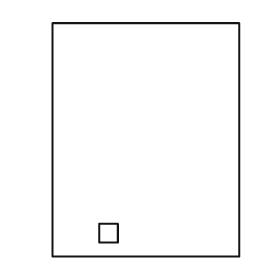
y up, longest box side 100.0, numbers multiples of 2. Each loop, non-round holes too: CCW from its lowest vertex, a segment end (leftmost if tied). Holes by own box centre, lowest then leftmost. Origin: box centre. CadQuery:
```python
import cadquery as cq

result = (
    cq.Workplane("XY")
    .moveTo(-40.0, -50.0)
    .lineTo(40.0, -50.0)
    .lineTo(40.0, 50.0)
    .lineTo(-40.0, 50.0)
    .close()
    .moveTo(-20.0, -44.0)
    .lineTo(-12.0, -44.0)
    .lineTo(-12.0, -36.0)
    .lineTo(-20.0, -36.0)
    .close()
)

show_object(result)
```